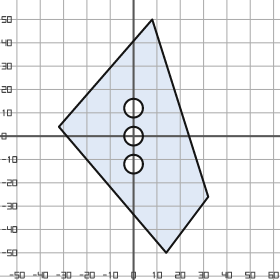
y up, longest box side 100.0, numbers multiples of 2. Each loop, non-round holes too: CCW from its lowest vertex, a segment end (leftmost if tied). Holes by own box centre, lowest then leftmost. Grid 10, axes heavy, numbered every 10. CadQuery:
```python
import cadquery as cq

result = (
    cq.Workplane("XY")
    .moveTo(14.0, -50.0)
    .lineTo(32.0, -26.0)
    .lineTo(8.0, 50.0)
    .lineTo(-32.0, 4.0)
    .close()
    .moveTo(0.0, -12.0)
    .circle(4.0)
    .moveTo(0.0, 0.0)
    .circle(4.0)
    .moveTo(0.0, 12.0)
    .circle(4.0)
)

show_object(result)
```